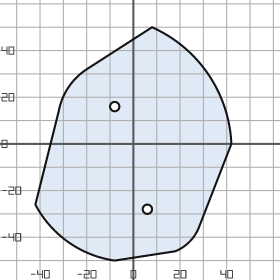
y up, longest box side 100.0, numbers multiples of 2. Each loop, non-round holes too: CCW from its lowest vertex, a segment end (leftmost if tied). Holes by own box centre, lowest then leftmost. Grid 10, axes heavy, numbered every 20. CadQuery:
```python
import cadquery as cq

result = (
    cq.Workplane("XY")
    .moveTo(-8.0, -50.0)
    .lineTo(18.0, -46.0)
    .threePointArc((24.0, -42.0), (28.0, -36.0))
    .lineTo(42.0, 0.0)
    .threePointArc((32.0, 30.0), (8.0, 50.0))
    .lineTo(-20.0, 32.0)
    .threePointArc((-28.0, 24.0), (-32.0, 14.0))
    .lineTo(-42.0, -26.0)
    .threePointArc((-28.0, -42.0), (-8.0, -50.0))
    .close()
    .moveTo(6.0, -28.0)
    .circle(2.0)
    .moveTo(-8.0, 16.0)
    .circle(2.0)
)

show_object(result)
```